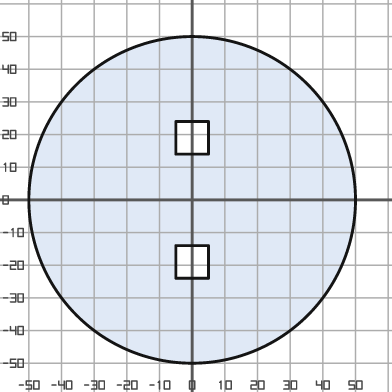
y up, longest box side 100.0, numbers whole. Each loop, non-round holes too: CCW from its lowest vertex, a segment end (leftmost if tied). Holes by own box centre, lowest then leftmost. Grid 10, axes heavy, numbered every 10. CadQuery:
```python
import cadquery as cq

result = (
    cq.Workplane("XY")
    .moveTo(0.0, 0.0)
    .circle(50.0)
    .moveTo(-5.0, -24.0)
    .lineTo(5.0, -24.0)
    .lineTo(5.0, -14.0)
    .lineTo(-5.0, -14.0)
    .close()
    .moveTo(-5.0, 14.0)
    .lineTo(5.0, 14.0)
    .lineTo(5.0, 24.0)
    .lineTo(-5.0, 24.0)
    .close()
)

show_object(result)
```